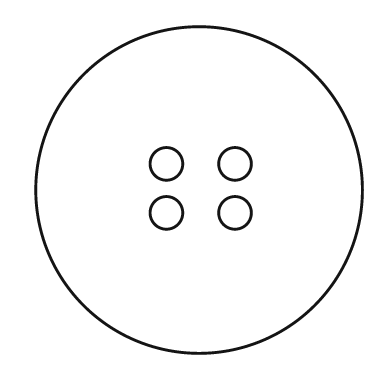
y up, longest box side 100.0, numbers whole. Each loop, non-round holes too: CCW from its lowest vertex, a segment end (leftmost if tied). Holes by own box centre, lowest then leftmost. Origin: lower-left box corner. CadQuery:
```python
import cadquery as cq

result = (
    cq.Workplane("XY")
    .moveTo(50.0, 50.0)
    .circle(50.0)
    .moveTo(40.0, 43.0)
    .circle(5.0)
    .moveTo(61.0, 43.0)
    .circle(5.0)
    .moveTo(40.0, 58.0)
    .circle(5.0)
    .moveTo(61.0, 58.0)
    .circle(5.0)
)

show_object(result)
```